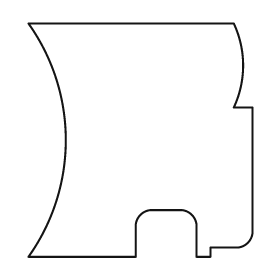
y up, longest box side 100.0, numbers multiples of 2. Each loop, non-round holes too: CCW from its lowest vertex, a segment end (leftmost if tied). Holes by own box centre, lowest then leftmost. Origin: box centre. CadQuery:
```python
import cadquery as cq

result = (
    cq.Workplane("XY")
    .moveTo(-48.0, -50.0)
    .lineTo(-2.0, -50.0)
    .lineTo(-2.0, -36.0)
    .threePointArc((0.0, -32.0), (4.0, -30.0))
    .lineTo(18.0, -30.0)
    .threePointArc((22.0, -32.0), (24.0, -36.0))
    .lineTo(24.0, -50.0)
    .lineTo(30.0, -50.0)
    .lineTo(30.0, -46.0)
    .lineTo(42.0, -46.0)
    .threePointArc((46.0, -44.0), (48.0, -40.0))
    .lineTo(48.0, 14.0)
    .lineTo(40.0, 14.0)
    .threePointArc((44.0, 32.0), (40.0, 50.0))
    .lineTo(-48.0, 50.0)
    .threePointArc((-32.0, 0.0), (-48.0, -50.0))
    .close()
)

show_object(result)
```